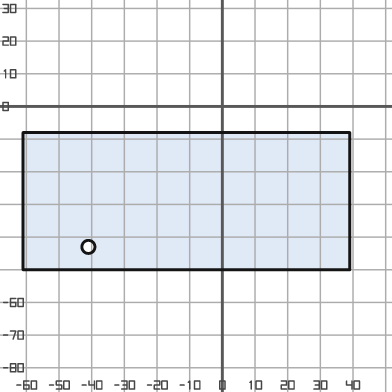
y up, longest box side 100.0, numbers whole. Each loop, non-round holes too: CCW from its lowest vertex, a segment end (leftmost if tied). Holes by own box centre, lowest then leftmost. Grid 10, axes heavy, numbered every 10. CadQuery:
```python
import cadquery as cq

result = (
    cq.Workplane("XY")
    .moveTo(-61.0, -50.0)
    .lineTo(39.0, -50.0)
    .lineTo(39.0, -8.0)
    .lineTo(-61.0, -8.0)
    .close()
    .moveTo(-41.0, -43.0)
    .circle(2.0)
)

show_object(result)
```